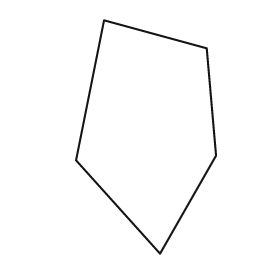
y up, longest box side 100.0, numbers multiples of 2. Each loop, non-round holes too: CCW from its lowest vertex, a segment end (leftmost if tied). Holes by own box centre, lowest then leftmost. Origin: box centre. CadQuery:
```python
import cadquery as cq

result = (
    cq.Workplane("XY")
    .moveTo(6.0, -50.0)
    .lineTo(30.0, -8.0)
    .lineTo(26.0, 38.0)
    .lineTo(-18.0, 50.0)
    .lineTo(-30.0, -10.0)
    .close()
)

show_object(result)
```